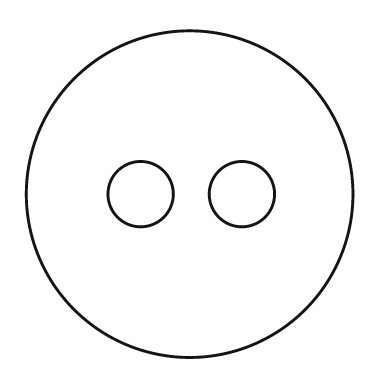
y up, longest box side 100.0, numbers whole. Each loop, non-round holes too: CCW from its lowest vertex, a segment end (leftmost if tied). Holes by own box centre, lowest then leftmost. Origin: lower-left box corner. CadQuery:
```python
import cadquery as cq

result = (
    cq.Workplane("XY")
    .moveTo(50.0, 50.0)
    .circle(50.0)
    .moveTo(35.0, 50.0)
    .circle(10.0)
    .moveTo(66.0, 50.0)
    .circle(10.0)
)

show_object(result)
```